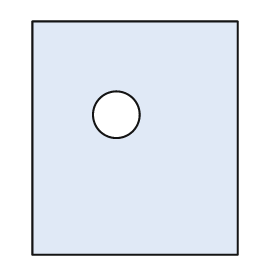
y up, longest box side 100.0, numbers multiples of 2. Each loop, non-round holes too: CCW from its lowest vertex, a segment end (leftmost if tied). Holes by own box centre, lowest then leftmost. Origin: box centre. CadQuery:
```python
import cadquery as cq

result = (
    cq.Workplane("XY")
    .moveTo(-44.0, -50.0)
    .lineTo(44.0, -50.0)
    .lineTo(44.0, 50.0)
    .lineTo(-44.0, 50.0)
    .close()
    .moveTo(-8.0, 10.0)
    .circle(10.0)
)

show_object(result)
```